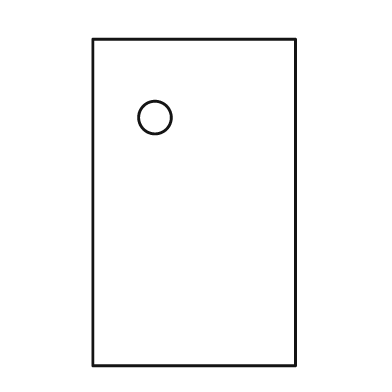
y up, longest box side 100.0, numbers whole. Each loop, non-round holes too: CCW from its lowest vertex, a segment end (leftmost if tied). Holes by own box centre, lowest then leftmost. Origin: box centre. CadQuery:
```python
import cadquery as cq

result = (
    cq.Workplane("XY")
    .moveTo(-31.0, -50.0)
    .lineTo(31.0, -50.0)
    .lineTo(31.0, 50.0)
    .lineTo(-31.0, 50.0)
    .close()
    .moveTo(-12.0, 26.0)
    .circle(5.0)
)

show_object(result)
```